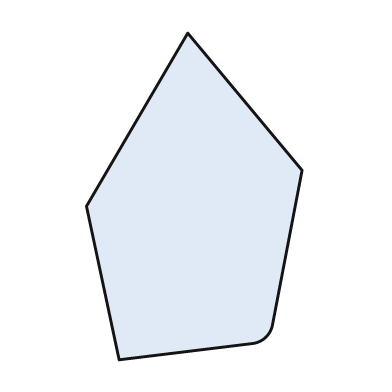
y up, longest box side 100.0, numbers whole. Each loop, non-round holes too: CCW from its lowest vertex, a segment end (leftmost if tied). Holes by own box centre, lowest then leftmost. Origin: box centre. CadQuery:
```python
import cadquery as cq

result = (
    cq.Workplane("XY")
    .moveTo(-23.0, -50.0)
    .lineTo(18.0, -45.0)
    .threePointArc((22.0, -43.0), (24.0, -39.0))
    .lineTo(33.0, 8.0)
    .lineTo(-2.0, 50.0)
    .lineTo(-33.0, -3.0)
    .close()
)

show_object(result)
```